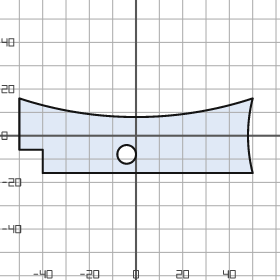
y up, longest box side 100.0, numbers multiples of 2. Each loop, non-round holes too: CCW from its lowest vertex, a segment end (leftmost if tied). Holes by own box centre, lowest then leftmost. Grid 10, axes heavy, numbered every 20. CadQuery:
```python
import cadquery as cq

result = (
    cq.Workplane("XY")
    .moveTo(-40.0, -16.0)
    .lineTo(50.0, -16.0)
    .threePointArc((48.0, 0.0), (50.0, 16.0))
    .threePointArc((0.0, 8.0), (-50.0, 16.0))
    .lineTo(-50.0, -6.0)
    .lineTo(-40.0, -6.0)
    .close()
    .moveTo(-4.0, -8.0)
    .circle(4.0)
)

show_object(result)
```